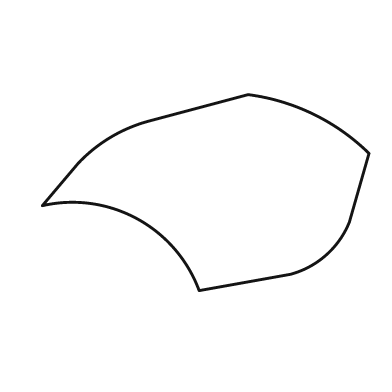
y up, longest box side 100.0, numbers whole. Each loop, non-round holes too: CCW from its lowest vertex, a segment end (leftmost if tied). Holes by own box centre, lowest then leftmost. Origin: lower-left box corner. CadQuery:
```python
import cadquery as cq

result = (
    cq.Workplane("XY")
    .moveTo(48.0, 0.0)
    .lineTo(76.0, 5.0)
    .threePointArc((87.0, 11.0), (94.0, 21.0))
    .lineTo(100.0, 42.0)
    .threePointArc((83.0, 54.0), (63.0, 60.0))
    .lineTo(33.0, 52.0)
    .threePointArc((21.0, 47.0), (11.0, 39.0))
    .lineTo(0.0, 26.0)
    .threePointArc((29.0, 22.0), (48.0, 0.0))
    .close()
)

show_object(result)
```